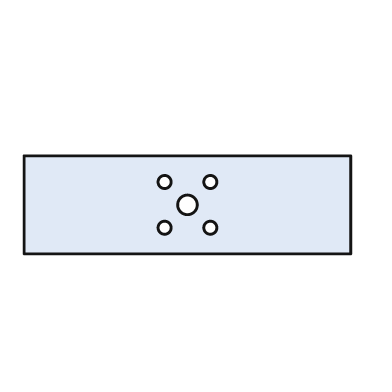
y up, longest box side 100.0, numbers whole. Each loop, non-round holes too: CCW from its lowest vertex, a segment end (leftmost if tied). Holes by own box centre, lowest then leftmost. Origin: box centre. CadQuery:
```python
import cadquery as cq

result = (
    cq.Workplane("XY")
    .moveTo(-50.0, -15.0)
    .lineTo(50.0, -15.0)
    .lineTo(50.0, 15.0)
    .lineTo(-50.0, 15.0)
    .close()
    .moveTo(-7.0, -7.0)
    .circle(2.0)
    .moveTo(7.0, -7.0)
    .circle(2.0)
    .moveTo(0.0, 0.0)
    .circle(3.0)
    .moveTo(-7.0, 7.0)
    .circle(2.0)
    .moveTo(7.0, 7.0)
    .circle(2.0)
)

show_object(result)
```